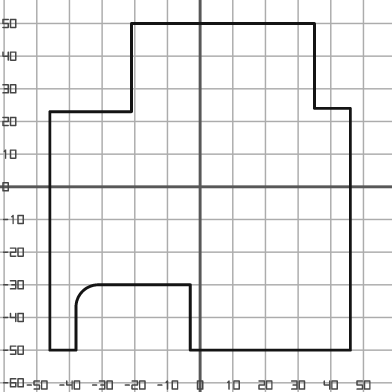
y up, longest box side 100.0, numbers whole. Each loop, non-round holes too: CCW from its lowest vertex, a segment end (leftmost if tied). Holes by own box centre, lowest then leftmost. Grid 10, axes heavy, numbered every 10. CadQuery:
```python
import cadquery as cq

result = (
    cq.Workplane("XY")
    .moveTo(-46.0, -50.0)
    .lineTo(-38.0, -50.0)
    .lineTo(-38.0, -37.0)
    .threePointArc((-36.0, -32.0), (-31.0, -30.0))
    .lineTo(-3.0, -30.0)
    .lineTo(-3.0, -50.0)
    .lineTo(46.0, -50.0)
    .lineTo(46.0, 24.0)
    .lineTo(35.0, 24.0)
    .lineTo(35.0, 50.0)
    .lineTo(-21.0, 50.0)
    .lineTo(-21.0, 23.0)
    .lineTo(-46.0, 23.0)
    .close()
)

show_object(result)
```